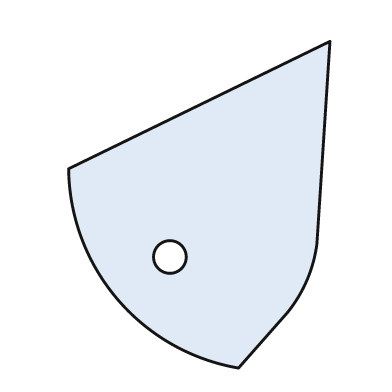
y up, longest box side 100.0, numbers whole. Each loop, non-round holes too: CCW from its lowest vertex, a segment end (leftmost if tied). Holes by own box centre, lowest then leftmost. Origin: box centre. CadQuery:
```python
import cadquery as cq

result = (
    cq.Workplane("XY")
    .moveTo(12.0, -50.0)
    .lineTo(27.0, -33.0)
    .threePointArc((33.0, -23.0), (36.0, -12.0))
    .lineTo(40.0, 50.0)
    .lineTo(-40.0, 11.0)
    .threePointArc((-25.0, -29.0), (12.0, -50.0))
    .close()
    .moveTo(-9.0, -16.0)
    .circle(5.0)
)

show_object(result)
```